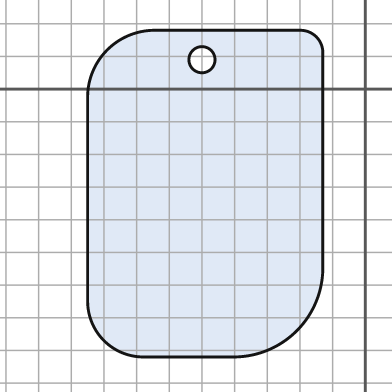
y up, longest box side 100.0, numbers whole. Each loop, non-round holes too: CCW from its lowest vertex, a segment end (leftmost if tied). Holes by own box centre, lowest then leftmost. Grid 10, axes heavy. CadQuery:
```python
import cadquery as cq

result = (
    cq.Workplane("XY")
    .moveTo(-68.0, -82.0)
    .lineTo(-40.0, -82.0)
    .threePointArc((-21.0, -74.0), (-13.0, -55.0))
    .lineTo(-13.0, 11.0)
    .threePointArc((-15.0, 16.0), (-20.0, 18.0))
    .lineTo(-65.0, 18.0)
    .threePointArc((-79.0, 12.0), (-85.0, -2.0))
    .lineTo(-85.0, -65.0)
    .threePointArc((-80.0, -77.0), (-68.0, -82.0))
    .close()
    .moveTo(-50.0, 9.0)
    .circle(4.0)
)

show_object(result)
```